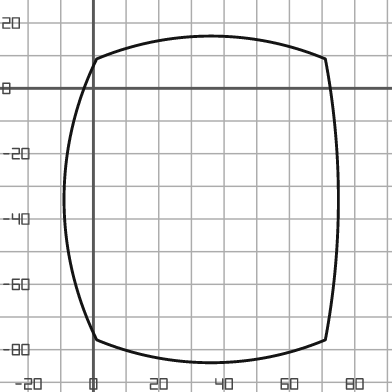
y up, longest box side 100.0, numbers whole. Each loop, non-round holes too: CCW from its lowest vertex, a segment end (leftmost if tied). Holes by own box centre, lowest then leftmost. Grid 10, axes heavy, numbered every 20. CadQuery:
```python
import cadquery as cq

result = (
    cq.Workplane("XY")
    .moveTo(1.0, -77.0)
    .threePointArc((36.0, -84.0), (71.0, -77.0))
    .threePointArc((75.0, -34.0), (71.0, 9.0))
    .threePointArc((36.0, 16.0), (1.0, 9.0))
    .threePointArc((-9.0, -34.0), (1.0, -77.0))
    .close()
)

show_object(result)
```